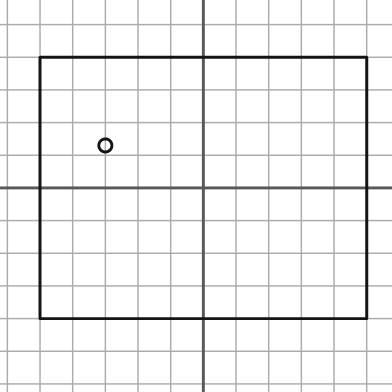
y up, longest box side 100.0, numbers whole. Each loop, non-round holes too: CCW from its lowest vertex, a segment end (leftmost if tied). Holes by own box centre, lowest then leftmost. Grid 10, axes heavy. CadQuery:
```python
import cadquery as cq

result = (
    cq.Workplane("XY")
    .moveTo(-50.0, -40.0)
    .lineTo(50.0, -40.0)
    .lineTo(50.0, 40.0)
    .lineTo(-50.0, 40.0)
    .close()
    .moveTo(-30.0, 13.0)
    .circle(2.0)
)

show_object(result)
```